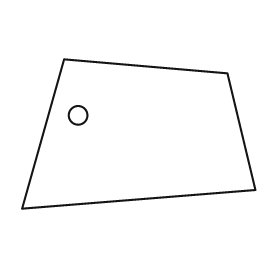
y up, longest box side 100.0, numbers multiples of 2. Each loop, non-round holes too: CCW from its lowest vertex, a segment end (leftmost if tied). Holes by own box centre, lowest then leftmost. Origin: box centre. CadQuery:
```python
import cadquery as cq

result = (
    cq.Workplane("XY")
    .moveTo(-50.0, -32.0)
    .lineTo(50.0, -24.0)
    .lineTo(38.0, 26.0)
    .lineTo(-32.0, 32.0)
    .close()
    .moveTo(-26.0, 8.0)
    .circle(4.0)
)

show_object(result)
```